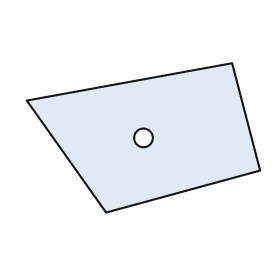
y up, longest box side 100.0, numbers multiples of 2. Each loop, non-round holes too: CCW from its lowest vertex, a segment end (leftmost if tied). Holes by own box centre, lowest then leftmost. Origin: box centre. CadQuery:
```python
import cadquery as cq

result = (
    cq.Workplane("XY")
    .moveTo(-16.0, -32.0)
    .lineTo(50.0, -14.0)
    .lineTo(38.0, 32.0)
    .lineTo(-50.0, 16.0)
    .close()
    .moveTo(0.0, 0.0)
    .circle(4.0)
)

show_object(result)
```